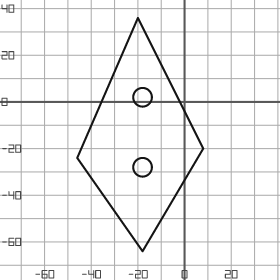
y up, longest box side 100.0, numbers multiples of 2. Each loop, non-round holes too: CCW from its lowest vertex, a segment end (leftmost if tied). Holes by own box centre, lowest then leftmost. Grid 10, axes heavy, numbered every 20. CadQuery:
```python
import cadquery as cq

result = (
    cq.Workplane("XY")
    .moveTo(-18.0, -64.0)
    .lineTo(8.0, -20.0)
    .lineTo(-20.0, 36.0)
    .lineTo(-46.0, -24.0)
    .close()
    .moveTo(-18.0, -28.0)
    .circle(4.0)
    .moveTo(-18.0, 2.0)
    .circle(4.0)
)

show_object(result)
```